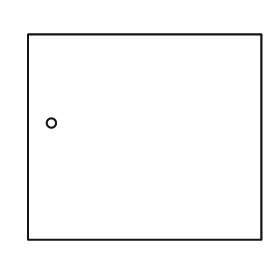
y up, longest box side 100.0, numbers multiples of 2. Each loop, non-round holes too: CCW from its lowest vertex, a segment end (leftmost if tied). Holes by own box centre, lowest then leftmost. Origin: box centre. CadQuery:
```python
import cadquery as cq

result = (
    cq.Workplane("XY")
    .moveTo(-50.0, -44.0)
    .lineTo(50.0, -44.0)
    .lineTo(50.0, 44.0)
    .lineTo(-50.0, 44.0)
    .close()
    .moveTo(-40.0, 6.0)
    .circle(2.0)
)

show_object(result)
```